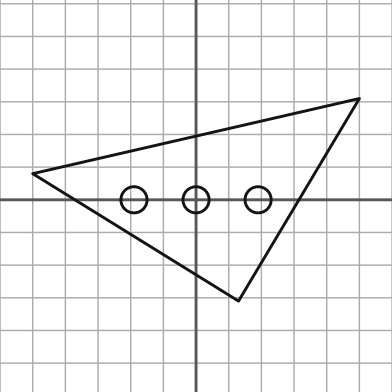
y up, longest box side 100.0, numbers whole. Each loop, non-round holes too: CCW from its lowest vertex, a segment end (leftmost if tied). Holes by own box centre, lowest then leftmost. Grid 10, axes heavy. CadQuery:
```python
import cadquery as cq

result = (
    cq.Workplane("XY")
    .moveTo(13.0, -31.0)
    .lineTo(50.0, 31.0)
    .lineTo(-50.0, 8.0)
    .close()
    .moveTo(-19.0, 0.0)
    .circle(4.0)
    .moveTo(0.0, 0.0)
    .circle(4.0)
    .moveTo(19.0, 0.0)
    .circle(4.0)
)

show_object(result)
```